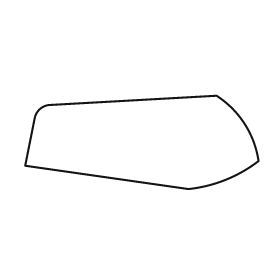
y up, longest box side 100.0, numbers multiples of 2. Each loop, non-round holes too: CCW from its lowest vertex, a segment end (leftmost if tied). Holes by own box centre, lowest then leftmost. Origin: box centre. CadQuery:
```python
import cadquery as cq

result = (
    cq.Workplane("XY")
    .moveTo(20.0, -20.0)
    .threePointArc((36.0, -16.0), (50.0, -8.0))
    .threePointArc((44.0, 8.0), (32.0, 20.0))
    .lineTo(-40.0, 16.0)
    .threePointArc((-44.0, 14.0), (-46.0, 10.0))
    .lineTo(-50.0, -10.0)
    .close()
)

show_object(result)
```